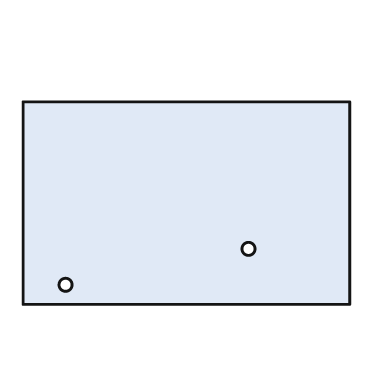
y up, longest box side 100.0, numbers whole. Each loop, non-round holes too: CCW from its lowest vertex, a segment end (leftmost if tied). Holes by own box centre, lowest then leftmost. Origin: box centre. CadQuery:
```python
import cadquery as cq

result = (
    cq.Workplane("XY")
    .moveTo(-50.0, -31.0)
    .lineTo(50.0, -31.0)
    .lineTo(50.0, 31.0)
    .lineTo(-50.0, 31.0)
    .close()
    .moveTo(-37.0, -25.0)
    .circle(2.0)
    .moveTo(19.0, -14.0)
    .circle(2.0)
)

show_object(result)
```